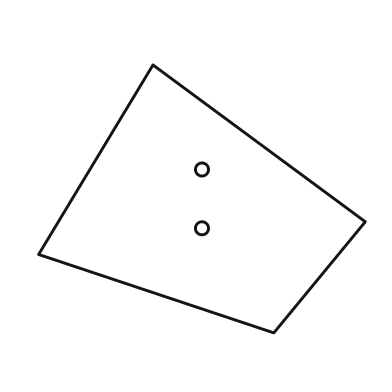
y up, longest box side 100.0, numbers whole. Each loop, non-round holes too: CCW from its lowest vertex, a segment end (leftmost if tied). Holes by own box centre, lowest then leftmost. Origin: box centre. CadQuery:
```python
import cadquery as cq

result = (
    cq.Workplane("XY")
    .moveTo(22.0, -41.0)
    .lineTo(50.0, -7.0)
    .lineTo(-15.0, 41.0)
    .lineTo(-50.0, -17.0)
    .close()
    .moveTo(0.0, -9.0)
    .circle(2.0)
    .moveTo(0.0, 9.0)
    .circle(2.0)
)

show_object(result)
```